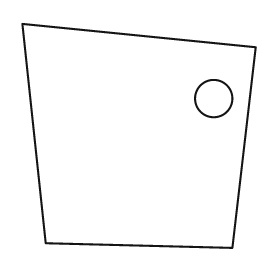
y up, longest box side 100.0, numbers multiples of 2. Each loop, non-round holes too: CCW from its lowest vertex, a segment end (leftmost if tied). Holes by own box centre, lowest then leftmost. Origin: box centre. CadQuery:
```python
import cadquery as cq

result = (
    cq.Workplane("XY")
    .moveTo(40.0, -48.0)
    .lineTo(50.0, 38.0)
    .lineTo(-50.0, 48.0)
    .lineTo(-40.0, -46.0)
    .close()
    .moveTo(32.0, 16.0)
    .circle(8.0)
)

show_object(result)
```